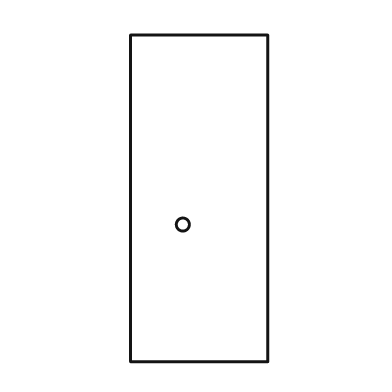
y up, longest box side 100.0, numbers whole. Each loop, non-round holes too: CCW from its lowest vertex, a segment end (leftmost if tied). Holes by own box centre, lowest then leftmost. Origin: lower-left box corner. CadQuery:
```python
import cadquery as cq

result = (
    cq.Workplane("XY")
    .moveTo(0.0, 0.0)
    .lineTo(42.0, 0.0)
    .lineTo(42.0, 100.0)
    .lineTo(0.0, 100.0)
    .close()
    .moveTo(16.0, 42.0)
    .circle(2.0)
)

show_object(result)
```